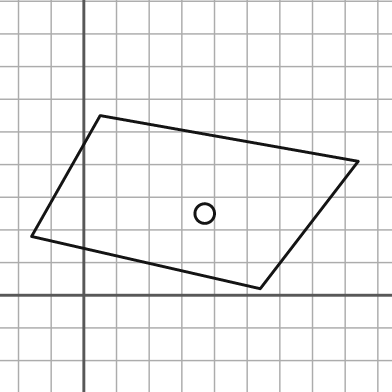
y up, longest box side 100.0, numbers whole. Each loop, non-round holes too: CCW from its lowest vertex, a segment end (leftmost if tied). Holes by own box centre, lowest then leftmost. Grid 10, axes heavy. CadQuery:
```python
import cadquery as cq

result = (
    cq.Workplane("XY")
    .moveTo(54.0, 2.0)
    .lineTo(84.0, 41.0)
    .lineTo(5.0, 55.0)
    .lineTo(-16.0, 18.0)
    .close()
    .moveTo(37.0, 25.0)
    .circle(3.0)
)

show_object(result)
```